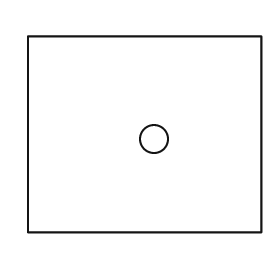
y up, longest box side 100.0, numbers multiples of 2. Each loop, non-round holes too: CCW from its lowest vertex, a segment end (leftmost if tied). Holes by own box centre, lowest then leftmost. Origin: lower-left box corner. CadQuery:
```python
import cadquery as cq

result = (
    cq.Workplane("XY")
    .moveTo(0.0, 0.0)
    .lineTo(100.0, 0.0)
    .lineTo(100.0, 84.0)
    .lineTo(0.0, 84.0)
    .close()
    .moveTo(54.0, 40.0)
    .circle(6.0)
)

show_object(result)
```